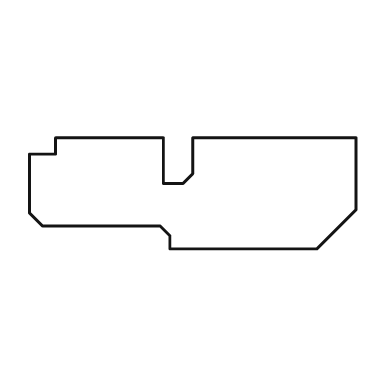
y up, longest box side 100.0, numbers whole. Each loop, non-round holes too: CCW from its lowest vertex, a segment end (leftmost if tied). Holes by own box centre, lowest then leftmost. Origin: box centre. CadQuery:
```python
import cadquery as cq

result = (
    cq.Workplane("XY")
    .moveTo(-7.0, -17.0)
    .lineTo(38.0, -17.0)
    .lineTo(50.0, -5.0)
    .lineTo(50.0, 17.0)
    .lineTo(0.0, 17.0)
    .lineTo(0.0, 6.0)
    .lineTo(-3.0, 3.0)
    .lineTo(-9.0, 3.0)
    .lineTo(-9.0, 17.0)
    .lineTo(-42.0, 17.0)
    .lineTo(-42.0, 12.0)
    .lineTo(-50.0, 12.0)
    .lineTo(-50.0, -6.0)
    .lineTo(-46.0, -10.0)
    .lineTo(-10.0, -10.0)
    .lineTo(-7.0, -13.0)
    .close()
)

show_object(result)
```